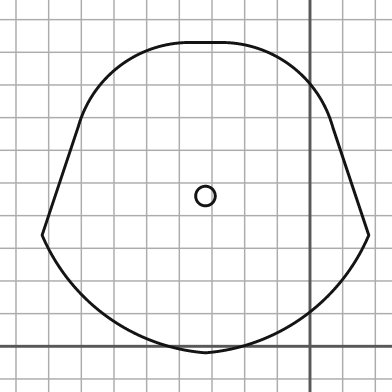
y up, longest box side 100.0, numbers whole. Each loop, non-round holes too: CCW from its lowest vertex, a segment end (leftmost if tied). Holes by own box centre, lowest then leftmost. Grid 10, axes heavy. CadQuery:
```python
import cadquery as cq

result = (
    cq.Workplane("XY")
    .moveTo(-32.0, -2.0)
    .threePointArc((-2.0, 9.0), (18.0, 34.0))
    .lineTo(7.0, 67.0)
    .threePointArc((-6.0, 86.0), (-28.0, 93.0))
    .lineTo(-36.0, 93.0)
    .threePointArc((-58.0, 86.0), (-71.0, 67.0))
    .lineTo(-82.0, 34.0)
    .threePointArc((-62.0, 9.0), (-32.0, -2.0))
    .close()
    .moveTo(-32.0, 46.0)
    .circle(3.0)
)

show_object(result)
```